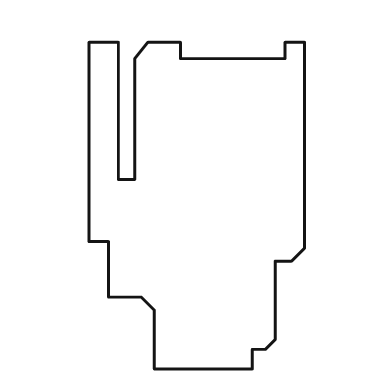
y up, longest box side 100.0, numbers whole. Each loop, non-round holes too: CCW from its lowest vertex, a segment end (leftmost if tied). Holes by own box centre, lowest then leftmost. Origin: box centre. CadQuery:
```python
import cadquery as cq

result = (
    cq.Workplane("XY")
    .moveTo(-13.0, -50.0)
    .lineTo(17.0, -50.0)
    .lineTo(17.0, -44.0)
    .lineTo(21.0, -44.0)
    .lineTo(24.0, -41.0)
    .lineTo(24.0, -17.0)
    .lineTo(29.0, -17.0)
    .lineTo(33.0, -13.0)
    .lineTo(33.0, 50.0)
    .lineTo(27.0, 50.0)
    .lineTo(27.0, 45.0)
    .lineTo(-5.0, 45.0)
    .lineTo(-5.0, 50.0)
    .lineTo(-15.0, 50.0)
    .lineTo(-19.0, 45.0)
    .lineTo(-19.0, 8.0)
    .lineTo(-24.0, 8.0)
    .lineTo(-24.0, 50.0)
    .lineTo(-33.0, 50.0)
    .lineTo(-33.0, -11.0)
    .lineTo(-27.0, -11.0)
    .lineTo(-27.0, -28.0)
    .lineTo(-17.0, -28.0)
    .lineTo(-13.0, -32.0)
    .close()
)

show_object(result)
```